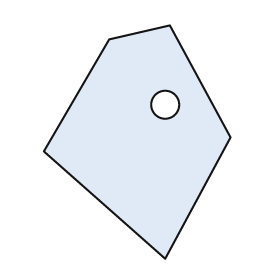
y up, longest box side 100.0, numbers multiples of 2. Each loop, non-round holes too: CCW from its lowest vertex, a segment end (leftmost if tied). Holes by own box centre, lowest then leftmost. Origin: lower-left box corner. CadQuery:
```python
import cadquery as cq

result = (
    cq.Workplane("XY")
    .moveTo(52.0, 0.0)
    .lineTo(80.0, 52.0)
    .lineTo(54.0, 100.0)
    .lineTo(28.0, 94.0)
    .lineTo(0.0, 46.0)
    .close()
    .moveTo(52.0, 66.0)
    .circle(6.0)
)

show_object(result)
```